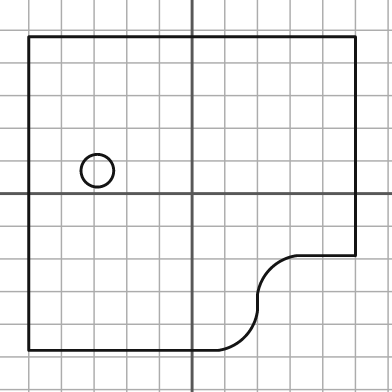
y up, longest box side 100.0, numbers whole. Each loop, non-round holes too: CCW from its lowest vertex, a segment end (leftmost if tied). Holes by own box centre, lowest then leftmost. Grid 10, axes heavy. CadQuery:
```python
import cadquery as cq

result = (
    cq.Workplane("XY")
    .moveTo(-50.0, -48.0)
    .lineTo(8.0, -48.0)
    .threePointArc((16.0, -44.0), (20.0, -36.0))
    .lineTo(20.0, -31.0)
    .threePointArc((24.0, -23.0), (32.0, -19.0))
    .lineTo(50.0, -19.0)
    .lineTo(50.0, 48.0)
    .lineTo(-50.0, 48.0)
    .close()
    .moveTo(-29.0, 7.0)
    .circle(5.0)
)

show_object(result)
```